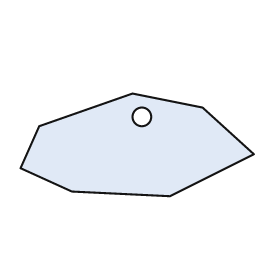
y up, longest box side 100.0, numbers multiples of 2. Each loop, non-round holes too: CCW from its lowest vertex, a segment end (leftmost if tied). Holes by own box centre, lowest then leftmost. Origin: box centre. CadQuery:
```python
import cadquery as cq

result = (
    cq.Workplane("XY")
    .moveTo(14.0, -22.0)
    .lineTo(50.0, -4.0)
    .lineTo(28.0, 16.0)
    .lineTo(-2.0, 22.0)
    .lineTo(-42.0, 8.0)
    .lineTo(-50.0, -10.0)
    .lineTo(-28.0, -20.0)
    .close()
    .moveTo(2.0, 12.0)
    .circle(4.0)
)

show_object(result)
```